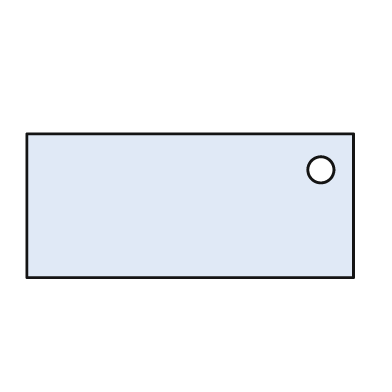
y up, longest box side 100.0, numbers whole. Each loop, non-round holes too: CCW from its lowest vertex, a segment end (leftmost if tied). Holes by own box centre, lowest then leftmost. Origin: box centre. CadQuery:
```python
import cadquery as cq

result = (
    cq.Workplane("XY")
    .moveTo(-50.0, -22.0)
    .lineTo(50.0, -22.0)
    .lineTo(50.0, 22.0)
    .lineTo(-50.0, 22.0)
    .close()
    .moveTo(40.0, 11.0)
    .circle(4.0)
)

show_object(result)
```